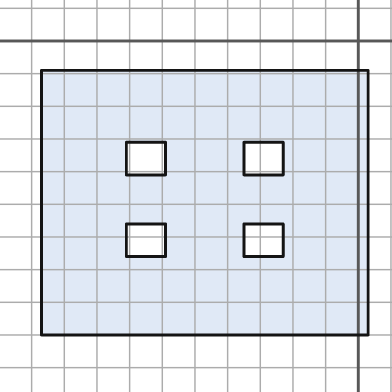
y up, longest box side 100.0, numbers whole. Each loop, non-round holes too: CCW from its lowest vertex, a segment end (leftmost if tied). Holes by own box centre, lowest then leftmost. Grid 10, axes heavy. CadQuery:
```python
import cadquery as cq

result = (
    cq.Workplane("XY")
    .moveTo(-97.0, -90.0)
    .lineTo(3.0, -90.0)
    .lineTo(3.0, -9.0)
    .lineTo(-97.0, -9.0)
    .close()
    .moveTo(-71.0, -66.0)
    .lineTo(-59.0, -66.0)
    .lineTo(-59.0, -56.0)
    .lineTo(-71.0, -56.0)
    .close()
    .moveTo(-35.0, -66.0)
    .lineTo(-23.0, -66.0)
    .lineTo(-23.0, -56.0)
    .lineTo(-35.0, -56.0)
    .close()
    .moveTo(-71.0, -41.0)
    .lineTo(-59.0, -41.0)
    .lineTo(-59.0, -31.0)
    .lineTo(-71.0, -31.0)
    .close()
    .moveTo(-35.0, -41.0)
    .lineTo(-23.0, -41.0)
    .lineTo(-23.0, -31.0)
    .lineTo(-35.0, -31.0)
    .close()
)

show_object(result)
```